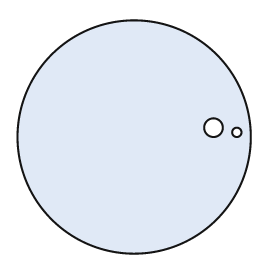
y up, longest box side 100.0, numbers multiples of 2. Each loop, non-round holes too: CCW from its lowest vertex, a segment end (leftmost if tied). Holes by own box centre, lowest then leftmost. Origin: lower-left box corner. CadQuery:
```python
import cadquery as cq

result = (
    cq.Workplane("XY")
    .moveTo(50.0, 50.0)
    .circle(50.0)
    .moveTo(94.0, 52.0)
    .circle(2.0)
    .moveTo(84.0, 54.0)
    .circle(4.0)
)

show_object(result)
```